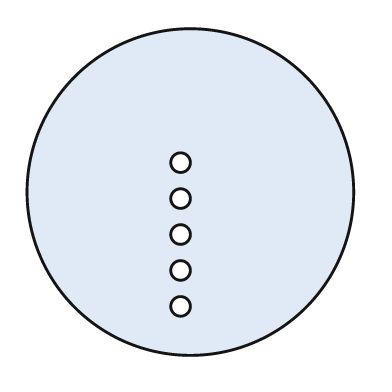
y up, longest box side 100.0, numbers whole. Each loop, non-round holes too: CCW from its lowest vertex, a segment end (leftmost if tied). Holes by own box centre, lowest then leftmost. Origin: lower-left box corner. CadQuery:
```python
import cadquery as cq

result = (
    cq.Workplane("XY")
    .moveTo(50.0, 50.0)
    .circle(50.0)
    .moveTo(47.0, 15.0)
    .circle(3.0)
    .moveTo(47.0, 26.0)
    .circle(3.0)
    .moveTo(47.0, 37.0)
    .circle(3.0)
    .moveTo(47.0, 48.0)
    .circle(3.0)
    .moveTo(47.0, 59.0)
    .circle(3.0)
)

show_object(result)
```